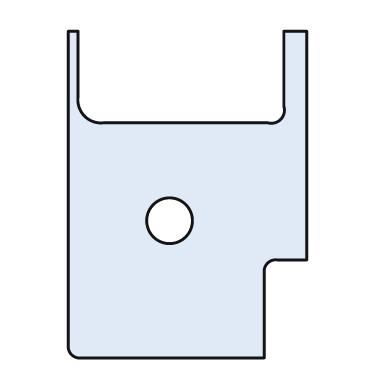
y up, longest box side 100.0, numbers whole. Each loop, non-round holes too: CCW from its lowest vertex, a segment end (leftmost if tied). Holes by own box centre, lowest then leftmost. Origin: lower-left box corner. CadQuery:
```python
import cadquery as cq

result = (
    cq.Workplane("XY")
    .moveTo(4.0, 0.0)
    .lineTo(60.0, 0.0)
    .lineTo(60.0, 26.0)
    .threePointArc((61.0, 29.0), (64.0, 30.0))
    .lineTo(73.0, 30.0)
    .lineTo(73.0, 100.0)
    .lineTo(66.0, 100.0)
    .lineTo(66.0, 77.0)
    .threePointArc((65.0, 73.0), (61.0, 72.0))
    .lineTo(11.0, 72.0)
    .threePointArc((5.0, 74.0), (3.0, 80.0))
    .lineTo(3.0, 100.0)
    .lineTo(0.0, 100.0)
    .lineTo(0.0, 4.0)
    .threePointArc((1.0, 1.0), (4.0, 0.0))
    .close()
    .moveTo(31.0, 42.0)
    .circle(7.0)
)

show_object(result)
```